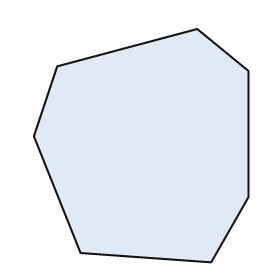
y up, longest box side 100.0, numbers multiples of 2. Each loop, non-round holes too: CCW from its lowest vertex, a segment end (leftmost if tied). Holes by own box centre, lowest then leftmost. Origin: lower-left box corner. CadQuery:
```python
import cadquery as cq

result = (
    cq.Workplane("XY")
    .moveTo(76.0, 0.0)
    .lineTo(92.0, 28.0)
    .lineTo(92.0, 82.0)
    .lineTo(70.0, 100.0)
    .lineTo(10.0, 84.0)
    .lineTo(0.0, 54.0)
    .lineTo(20.0, 4.0)
    .close()
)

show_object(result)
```